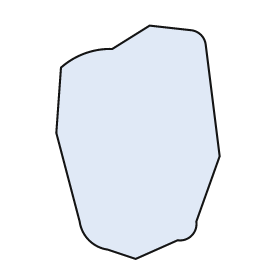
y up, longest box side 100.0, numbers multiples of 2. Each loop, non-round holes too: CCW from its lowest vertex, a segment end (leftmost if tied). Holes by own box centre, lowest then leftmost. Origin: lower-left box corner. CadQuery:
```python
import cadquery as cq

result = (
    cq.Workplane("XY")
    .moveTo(34.0, 0.0)
    .lineTo(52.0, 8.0)
    .threePointArc((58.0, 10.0), (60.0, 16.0))
    .lineTo(70.0, 44.0)
    .lineTo(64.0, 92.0)
    .threePointArc((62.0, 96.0), (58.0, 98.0))
    .lineTo(40.0, 100.0)
    .lineTo(24.0, 90.0)
    .threePointArc((12.0, 88.0), (2.0, 82.0))
    .lineTo(0.0, 54.0)
    .lineTo(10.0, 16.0)
    .threePointArc((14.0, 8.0), (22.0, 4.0))
    .close()
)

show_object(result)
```